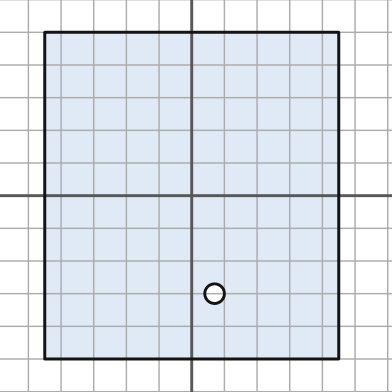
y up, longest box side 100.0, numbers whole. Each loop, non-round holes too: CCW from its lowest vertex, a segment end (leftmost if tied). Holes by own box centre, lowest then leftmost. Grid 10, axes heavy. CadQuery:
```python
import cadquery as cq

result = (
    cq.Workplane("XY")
    .moveTo(-45.0, -50.0)
    .lineTo(45.0, -50.0)
    .lineTo(45.0, 50.0)
    .lineTo(-45.0, 50.0)
    .close()
    .moveTo(7.0, -30.0)
    .circle(3.0)
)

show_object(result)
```